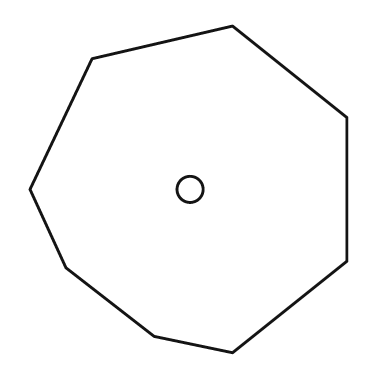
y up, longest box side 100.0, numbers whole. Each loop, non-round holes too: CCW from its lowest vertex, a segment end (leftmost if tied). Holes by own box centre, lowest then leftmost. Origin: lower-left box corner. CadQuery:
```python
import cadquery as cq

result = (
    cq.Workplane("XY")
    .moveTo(62.0, 0.0)
    .lineTo(97.0, 28.0)
    .lineTo(97.0, 72.0)
    .lineTo(62.0, 100.0)
    .lineTo(19.0, 90.0)
    .lineTo(0.0, 50.0)
    .lineTo(11.0, 26.0)
    .lineTo(38.0, 5.0)
    .close()
    .moveTo(49.0, 50.0)
    .circle(4.0)
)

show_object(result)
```